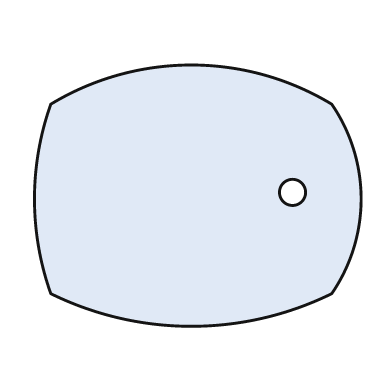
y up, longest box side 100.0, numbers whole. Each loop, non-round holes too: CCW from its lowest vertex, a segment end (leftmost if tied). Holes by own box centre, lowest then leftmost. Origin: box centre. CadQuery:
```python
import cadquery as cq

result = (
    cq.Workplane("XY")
    .moveTo(-45.0, -30.0)
    .threePointArc((-2.0, -40.0), (41.0, -30.0))
    .threePointArc((50.0, -1.0), (41.0, 28.0))
    .threePointArc((-2.0, 40.0), (-45.0, 28.0))
    .threePointArc((-50.0, -1.0), (-45.0, -30.0))
    .close()
    .moveTo(29.0, 1.0)
    .circle(4.0)
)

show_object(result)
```